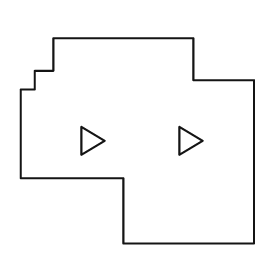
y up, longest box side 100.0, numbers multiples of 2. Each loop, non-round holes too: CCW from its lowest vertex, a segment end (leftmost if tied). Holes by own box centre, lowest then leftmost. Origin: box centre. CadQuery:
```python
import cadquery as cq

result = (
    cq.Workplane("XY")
    .moveTo(-6.0, -44.0)
    .lineTo(50.0, -44.0)
    .lineTo(50.0, 26.0)
    .lineTo(24.0, 26.0)
    .lineTo(24.0, 44.0)
    .lineTo(-36.0, 44.0)
    .lineTo(-36.0, 30.0)
    .lineTo(-44.0, 30.0)
    .lineTo(-44.0, 22.0)
    .lineTo(-50.0, 22.0)
    .lineTo(-50.0, -16.0)
    .lineTo(-6.0, -16.0)
    .close()
    .moveTo(-24.0, -6.0)
    .lineTo(-14.0, 0.0)
    .lineTo(-24.0, 6.0)
    .close()
    .moveTo(18.0, -6.0)
    .lineTo(28.0, 0.0)
    .lineTo(18.0, 6.0)
    .close()
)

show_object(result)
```